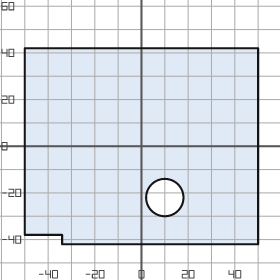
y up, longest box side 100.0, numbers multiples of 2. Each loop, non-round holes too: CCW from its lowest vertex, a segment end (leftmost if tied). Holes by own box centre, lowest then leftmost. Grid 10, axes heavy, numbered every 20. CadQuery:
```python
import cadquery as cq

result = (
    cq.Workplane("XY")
    .moveTo(-34.0, -42.0)
    .lineTo(50.0, -42.0)
    .lineTo(50.0, 42.0)
    .lineTo(-50.0, 42.0)
    .lineTo(-50.0, -38.0)
    .lineTo(-34.0, -38.0)
    .close()
    .moveTo(10.0, -22.0)
    .circle(8.0)
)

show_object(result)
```